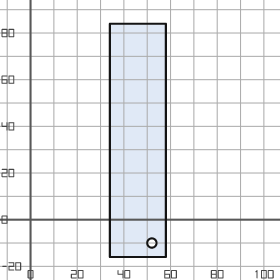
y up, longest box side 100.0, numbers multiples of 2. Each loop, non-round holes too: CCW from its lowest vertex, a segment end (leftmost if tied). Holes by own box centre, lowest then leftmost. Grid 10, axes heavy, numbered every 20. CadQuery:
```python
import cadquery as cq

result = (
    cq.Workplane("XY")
    .moveTo(34.0, -16.0)
    .lineTo(58.0, -16.0)
    .lineTo(58.0, 84.0)
    .lineTo(34.0, 84.0)
    .close()
    .moveTo(52.0, -10.0)
    .circle(2.0)
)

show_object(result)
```